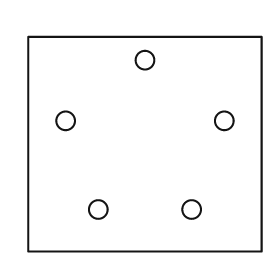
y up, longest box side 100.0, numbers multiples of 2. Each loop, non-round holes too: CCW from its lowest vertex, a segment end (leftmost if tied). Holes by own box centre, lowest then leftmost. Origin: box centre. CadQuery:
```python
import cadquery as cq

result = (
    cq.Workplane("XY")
    .moveTo(-50.0, -46.0)
    .lineTo(50.0, -46.0)
    .lineTo(50.0, 46.0)
    .lineTo(-50.0, 46.0)
    .close()
    .moveTo(-20.0, -28.0)
    .circle(4.0)
    .moveTo(20.0, -28.0)
    .circle(4.0)
    .moveTo(-34.0, 10.0)
    .circle(4.0)
    .moveTo(34.0, 10.0)
    .circle(4.0)
    .moveTo(0.0, 36.0)
    .circle(4.0)
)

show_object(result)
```